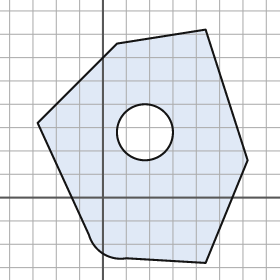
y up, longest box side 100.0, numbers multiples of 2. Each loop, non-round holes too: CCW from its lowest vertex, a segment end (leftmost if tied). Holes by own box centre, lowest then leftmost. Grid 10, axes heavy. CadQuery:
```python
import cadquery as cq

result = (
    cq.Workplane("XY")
    .moveTo(44.0, -28.0)
    .lineTo(62.0, 16.0)
    .lineTo(44.0, 72.0)
    .lineTo(6.0, 66.0)
    .lineTo(-28.0, 32.0)
    .lineTo(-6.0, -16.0)
    .threePointArc((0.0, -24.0), (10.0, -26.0))
    .close()
    .moveTo(18.0, 28.0)
    .circle(12.0)
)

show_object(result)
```